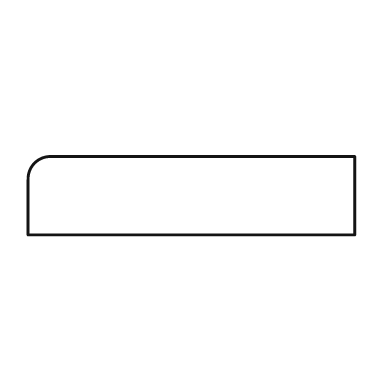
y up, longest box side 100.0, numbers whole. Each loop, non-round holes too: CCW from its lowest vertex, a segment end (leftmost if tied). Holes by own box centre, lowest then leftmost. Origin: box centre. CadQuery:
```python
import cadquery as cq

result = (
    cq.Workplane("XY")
    .moveTo(-50.0, -12.0)
    .lineTo(50.0, -12.0)
    .lineTo(50.0, 12.0)
    .lineTo(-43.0, 12.0)
    .threePointArc((-48.0, 10.0), (-50.0, 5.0))
    .close()
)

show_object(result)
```